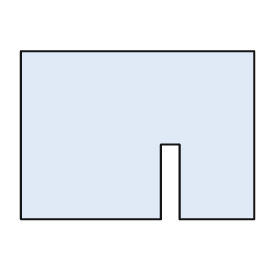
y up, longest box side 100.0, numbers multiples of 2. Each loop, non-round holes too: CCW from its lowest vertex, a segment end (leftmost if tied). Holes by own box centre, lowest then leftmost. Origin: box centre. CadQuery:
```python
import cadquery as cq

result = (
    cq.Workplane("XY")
    .moveTo(-50.0, -36.0)
    .lineTo(10.0, -36.0)
    .lineTo(10.0, -4.0)
    .lineTo(18.0, -4.0)
    .lineTo(18.0, -36.0)
    .lineTo(50.0, -36.0)
    .lineTo(50.0, 36.0)
    .lineTo(-50.0, 36.0)
    .close()
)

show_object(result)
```